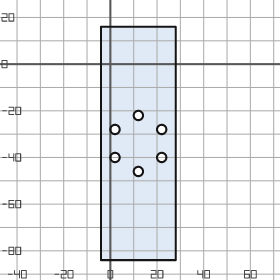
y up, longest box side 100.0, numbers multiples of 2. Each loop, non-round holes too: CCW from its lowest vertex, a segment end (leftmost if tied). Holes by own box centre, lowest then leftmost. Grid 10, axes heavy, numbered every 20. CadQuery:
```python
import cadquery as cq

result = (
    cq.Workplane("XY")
    .moveTo(-4.0, -84.0)
    .lineTo(28.0, -84.0)
    .lineTo(28.0, 16.0)
    .lineTo(-4.0, 16.0)
    .close()
    .moveTo(12.0, -46.0)
    .circle(2.0)
    .moveTo(2.0, -40.0)
    .circle(2.0)
    .moveTo(22.0, -40.0)
    .circle(2.0)
    .moveTo(2.0, -28.0)
    .circle(2.0)
    .moveTo(22.0, -28.0)
    .circle(2.0)
    .moveTo(12.0, -22.0)
    .circle(2.0)
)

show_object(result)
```